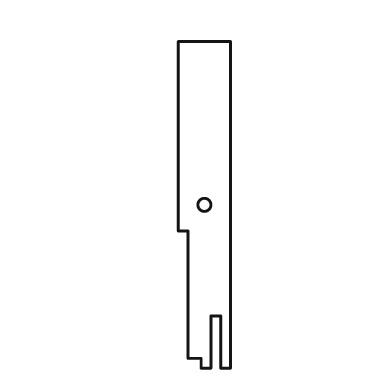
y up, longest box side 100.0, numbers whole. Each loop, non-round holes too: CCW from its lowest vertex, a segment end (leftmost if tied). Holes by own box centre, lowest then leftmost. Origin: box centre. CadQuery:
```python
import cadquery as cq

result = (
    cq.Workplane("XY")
    .moveTo(-1.0, -50.0)
    .lineTo(2.0, -50.0)
    .lineTo(2.0, -34.0)
    .lineTo(5.0, -34.0)
    .lineTo(5.0, -50.0)
    .lineTo(8.0, -50.0)
    .lineTo(8.0, 50.0)
    .lineTo(-8.0, 50.0)
    .lineTo(-8.0, -8.0)
    .lineTo(-5.0, -8.0)
    .lineTo(-5.0, -47.0)
    .lineTo(-1.0, -47.0)
    .close()
    .moveTo(0.0, 0.0)
    .circle(2.0)
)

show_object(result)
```